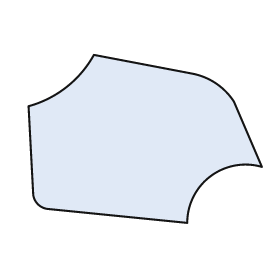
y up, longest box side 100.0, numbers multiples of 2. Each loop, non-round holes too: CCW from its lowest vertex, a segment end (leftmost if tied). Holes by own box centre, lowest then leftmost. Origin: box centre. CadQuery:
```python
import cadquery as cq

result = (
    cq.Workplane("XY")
    .moveTo(18.0, -36.0)
    .threePointArc((28.0, -16.0), (50.0, -12.0))
    .lineTo(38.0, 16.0)
    .threePointArc((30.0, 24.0), (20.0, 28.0))
    .lineTo(-22.0, 36.0)
    .threePointArc((-34.0, 22.0), (-50.0, 14.0))
    .lineTo(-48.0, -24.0)
    .threePointArc((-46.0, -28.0), (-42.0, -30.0))
    .close()
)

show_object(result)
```